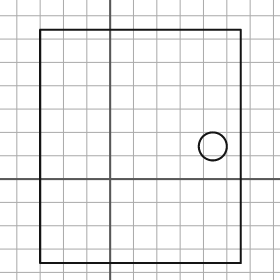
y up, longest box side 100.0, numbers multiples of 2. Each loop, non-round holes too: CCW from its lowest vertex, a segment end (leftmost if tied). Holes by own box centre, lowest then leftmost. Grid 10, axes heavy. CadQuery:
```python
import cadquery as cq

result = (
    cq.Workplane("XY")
    .moveTo(-30.0, -36.0)
    .lineTo(56.0, -36.0)
    .lineTo(56.0, 64.0)
    .lineTo(-30.0, 64.0)
    .close()
    .moveTo(44.0, 14.0)
    .circle(6.0)
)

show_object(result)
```